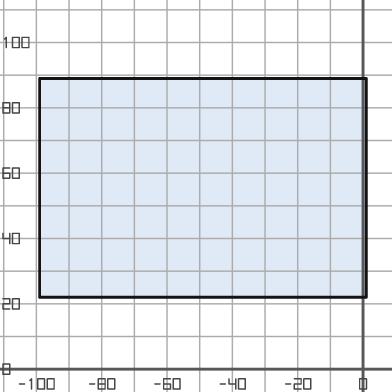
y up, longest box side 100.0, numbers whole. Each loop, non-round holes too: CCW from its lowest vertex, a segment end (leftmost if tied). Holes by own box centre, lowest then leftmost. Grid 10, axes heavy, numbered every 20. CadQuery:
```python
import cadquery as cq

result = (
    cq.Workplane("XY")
    .moveTo(-99.0, 22.0)
    .lineTo(1.0, 22.0)
    .lineTo(1.0, 89.0)
    .lineTo(-99.0, 89.0)
    .close()
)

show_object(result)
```